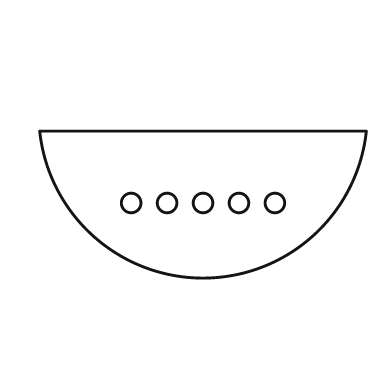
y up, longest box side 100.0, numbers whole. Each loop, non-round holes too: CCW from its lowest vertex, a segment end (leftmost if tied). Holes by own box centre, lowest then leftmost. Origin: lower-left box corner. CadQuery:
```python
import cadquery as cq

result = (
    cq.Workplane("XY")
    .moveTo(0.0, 45.0)
    .threePointArc((50.0, 0.0), (100.0, 45.0))
    .close()
    .moveTo(28.0, 23.0)
    .circle(3.0)
    .moveTo(39.0, 23.0)
    .circle(3.0)
    .moveTo(50.0, 23.0)
    .circle(3.0)
    .moveTo(61.0, 23.0)
    .circle(3.0)
    .moveTo(72.0, 23.0)
    .circle(3.0)
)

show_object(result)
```